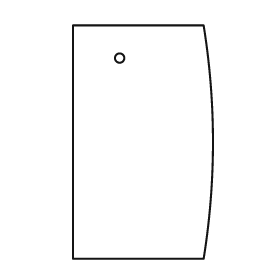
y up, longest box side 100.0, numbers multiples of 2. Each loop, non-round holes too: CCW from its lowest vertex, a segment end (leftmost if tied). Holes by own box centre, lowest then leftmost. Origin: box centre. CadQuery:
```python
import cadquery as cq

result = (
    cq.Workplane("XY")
    .moveTo(-30.0, -50.0)
    .lineTo(26.0, -50.0)
    .threePointArc((30.0, 0.0), (26.0, 50.0))
    .lineTo(-30.0, 50.0)
    .close()
    .moveTo(-10.0, 36.0)
    .circle(2.0)
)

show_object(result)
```